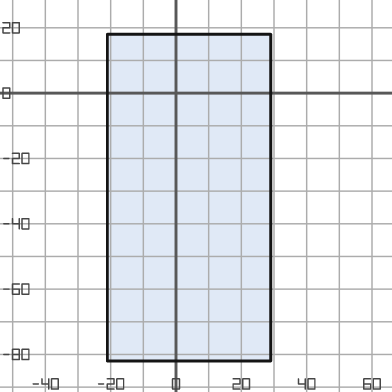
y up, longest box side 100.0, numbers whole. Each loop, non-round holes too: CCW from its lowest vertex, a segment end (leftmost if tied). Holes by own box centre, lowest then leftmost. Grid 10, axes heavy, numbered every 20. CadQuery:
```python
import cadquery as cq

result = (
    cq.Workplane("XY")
    .moveTo(-21.0, -82.0)
    .lineTo(29.0, -82.0)
    .lineTo(29.0, 18.0)
    .lineTo(-21.0, 18.0)
    .close()
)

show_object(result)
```